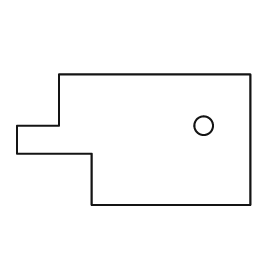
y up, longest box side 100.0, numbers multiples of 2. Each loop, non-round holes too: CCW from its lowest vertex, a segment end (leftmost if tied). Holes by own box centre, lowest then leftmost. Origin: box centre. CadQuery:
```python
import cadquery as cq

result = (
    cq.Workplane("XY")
    .moveTo(-18.0, -28.0)
    .lineTo(50.0, -28.0)
    .lineTo(50.0, 28.0)
    .lineTo(-32.0, 28.0)
    .lineTo(-32.0, 6.0)
    .lineTo(-50.0, 6.0)
    .lineTo(-50.0, -6.0)
    .lineTo(-18.0, -6.0)
    .close()
    .moveTo(30.0, 6.0)
    .circle(4.0)
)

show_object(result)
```